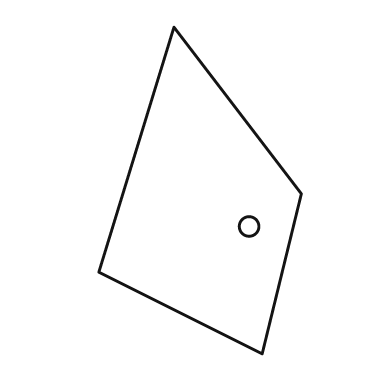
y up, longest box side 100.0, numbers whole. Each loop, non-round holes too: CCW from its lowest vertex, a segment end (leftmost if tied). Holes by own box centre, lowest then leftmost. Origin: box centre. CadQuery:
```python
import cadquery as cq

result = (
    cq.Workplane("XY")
    .moveTo(19.0, -50.0)
    .lineTo(31.0, -1.0)
    .lineTo(-8.0, 50.0)
    .lineTo(-31.0, -25.0)
    .close()
    .moveTo(15.0, -11.0)
    .circle(3.0)
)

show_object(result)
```